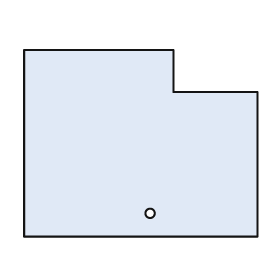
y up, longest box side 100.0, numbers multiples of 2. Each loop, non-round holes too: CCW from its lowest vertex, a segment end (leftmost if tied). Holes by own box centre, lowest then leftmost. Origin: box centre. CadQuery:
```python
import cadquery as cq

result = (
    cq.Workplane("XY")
    .moveTo(-50.0, -40.0)
    .lineTo(50.0, -40.0)
    .lineTo(50.0, 22.0)
    .lineTo(14.0, 22.0)
    .lineTo(14.0, 40.0)
    .lineTo(-50.0, 40.0)
    .close()
    .moveTo(4.0, -30.0)
    .circle(2.0)
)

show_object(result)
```